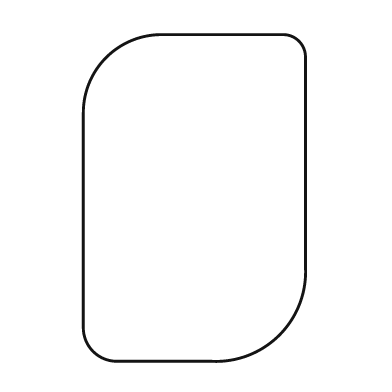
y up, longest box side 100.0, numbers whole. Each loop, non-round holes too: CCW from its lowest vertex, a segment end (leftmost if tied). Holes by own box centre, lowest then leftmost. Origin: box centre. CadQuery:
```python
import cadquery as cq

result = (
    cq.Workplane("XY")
    .moveTo(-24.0, -50.0)
    .lineTo(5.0, -50.0)
    .threePointArc((26.0, -42.0), (34.0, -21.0))
    .lineTo(34.0, 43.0)
    .threePointArc((32.0, 48.0), (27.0, 50.0))
    .lineTo(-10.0, 50.0)
    .threePointArc((-27.0, 43.0), (-34.0, 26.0))
    .lineTo(-34.0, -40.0)
    .threePointArc((-31.0, -47.0), (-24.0, -50.0))
    .close()
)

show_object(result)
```